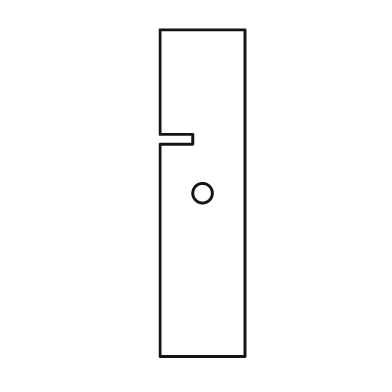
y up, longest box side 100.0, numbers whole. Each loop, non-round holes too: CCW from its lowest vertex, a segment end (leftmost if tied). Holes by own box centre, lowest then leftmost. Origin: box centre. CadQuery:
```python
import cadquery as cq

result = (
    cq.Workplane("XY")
    .moveTo(-13.0, -50.0)
    .lineTo(13.0, -50.0)
    .lineTo(13.0, 50.0)
    .lineTo(-13.0, 50.0)
    .lineTo(-13.0, 18.0)
    .lineTo(-3.0, 18.0)
    .lineTo(-3.0, 15.0)
    .lineTo(-13.0, 15.0)
    .close()
    .moveTo(0.0, 0.0)
    .circle(3.0)
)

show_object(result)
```